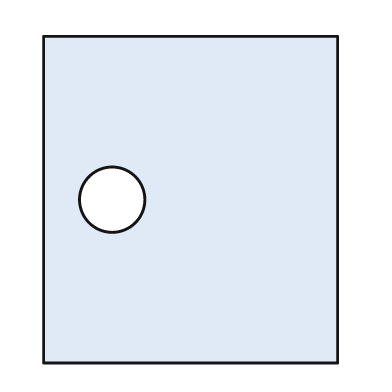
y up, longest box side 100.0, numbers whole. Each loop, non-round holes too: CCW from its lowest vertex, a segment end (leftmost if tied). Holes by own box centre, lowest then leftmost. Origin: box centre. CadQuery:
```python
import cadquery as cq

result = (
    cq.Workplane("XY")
    .moveTo(-45.0, -50.0)
    .lineTo(45.0, -50.0)
    .lineTo(45.0, 50.0)
    .lineTo(-45.0, 50.0)
    .close()
    .moveTo(-24.0, 0.0)
    .circle(10.0)
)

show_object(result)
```